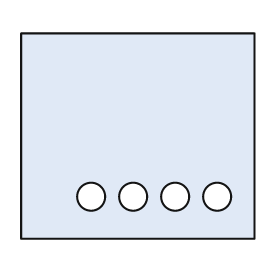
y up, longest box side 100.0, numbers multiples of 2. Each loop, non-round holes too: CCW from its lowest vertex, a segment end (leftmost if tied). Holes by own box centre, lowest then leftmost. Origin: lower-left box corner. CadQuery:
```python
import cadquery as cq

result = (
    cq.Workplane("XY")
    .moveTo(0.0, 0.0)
    .lineTo(100.0, 0.0)
    .lineTo(100.0, 88.0)
    .lineTo(0.0, 88.0)
    .close()
    .moveTo(30.0, 18.0)
    .circle(6.0)
    .moveTo(48.0, 18.0)
    .circle(6.0)
    .moveTo(66.0, 18.0)
    .circle(6.0)
    .moveTo(84.0, 18.0)
    .circle(6.0)
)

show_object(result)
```